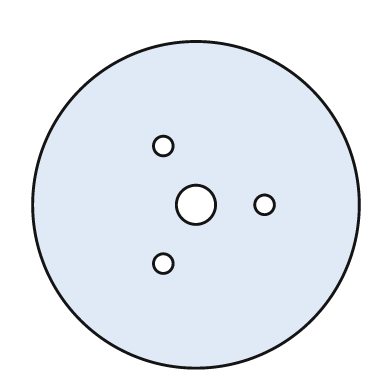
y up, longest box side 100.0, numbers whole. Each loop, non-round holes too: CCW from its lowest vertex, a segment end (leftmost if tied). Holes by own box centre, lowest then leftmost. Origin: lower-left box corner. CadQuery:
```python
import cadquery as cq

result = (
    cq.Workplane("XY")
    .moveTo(50.0, 50.0)
    .circle(50.0)
    .moveTo(40.0, 32.0)
    .circle(3.0)
    .moveTo(50.0, 50.0)
    .circle(6.0)
    .moveTo(71.0, 50.0)
    .circle(3.0)
    .moveTo(40.0, 68.0)
    .circle(3.0)
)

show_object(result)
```